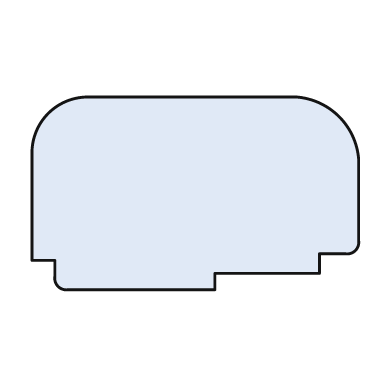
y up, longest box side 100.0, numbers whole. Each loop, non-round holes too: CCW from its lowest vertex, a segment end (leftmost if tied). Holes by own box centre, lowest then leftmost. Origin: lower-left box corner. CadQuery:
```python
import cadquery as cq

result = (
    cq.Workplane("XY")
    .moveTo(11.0, 0.0)
    .lineTo(56.0, 0.0)
    .lineTo(56.0, 5.0)
    .lineTo(88.0, 5.0)
    .lineTo(88.0, 11.0)
    .lineTo(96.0, 11.0)
    .threePointArc((99.0, 12.0), (100.0, 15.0))
    .lineTo(100.0, 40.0)
    .threePointArc((94.0, 53.0), (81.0, 59.0))
    .lineTo(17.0, 59.0)
    .threePointArc((5.0, 54.0), (0.0, 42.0))
    .lineTo(0.0, 9.0)
    .lineTo(7.0, 9.0)
    .lineTo(7.0, 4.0)
    .threePointArc((8.0, 1.0), (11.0, 0.0))
    .close()
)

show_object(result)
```